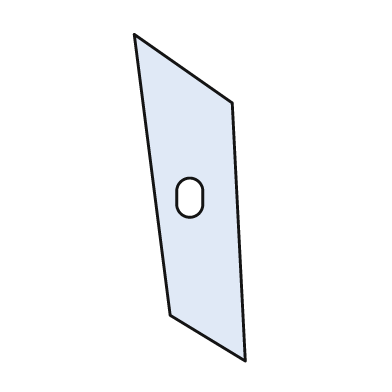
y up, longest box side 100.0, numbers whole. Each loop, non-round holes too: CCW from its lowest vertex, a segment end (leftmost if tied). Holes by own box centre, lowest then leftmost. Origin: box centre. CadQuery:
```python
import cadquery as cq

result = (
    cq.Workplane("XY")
    .moveTo(17.0, -50.0)
    .lineTo(13.0, 29.0)
    .lineTo(-17.0, 50.0)
    .lineTo(-6.0, -36.0)
    .close()
    .moveTo(-4.0, -2.0)
    .threePointArc((0.0, -6.0), (4.0, -2.0))
    .lineTo(4.0, 2.0)
    .threePointArc((0.0, 6.0), (-4.0, 2.0))
    .close()
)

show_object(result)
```